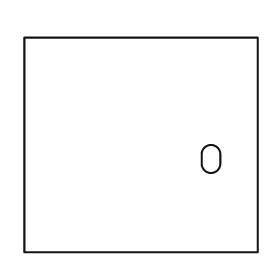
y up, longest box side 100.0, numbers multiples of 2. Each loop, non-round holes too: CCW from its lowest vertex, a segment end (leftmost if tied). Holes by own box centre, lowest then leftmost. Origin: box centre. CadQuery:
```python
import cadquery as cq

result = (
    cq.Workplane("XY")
    .moveTo(-50.0, -46.0)
    .lineTo(50.0, -46.0)
    .lineTo(50.0, 46.0)
    .lineTo(-50.0, 46.0)
    .close()
    .moveTo(26.0, -8.0)
    .threePointArc((30.0, -12.0), (34.0, -8.0))
    .lineTo(34.0, -4.0)
    .threePointArc((30.0, 0.0), (26.0, -4.0))
    .close()
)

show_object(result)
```